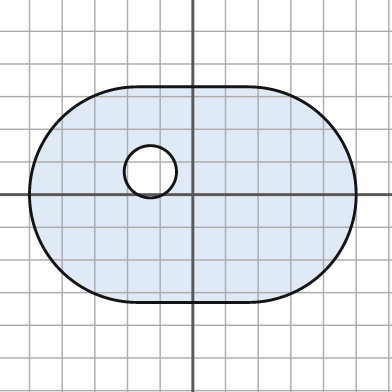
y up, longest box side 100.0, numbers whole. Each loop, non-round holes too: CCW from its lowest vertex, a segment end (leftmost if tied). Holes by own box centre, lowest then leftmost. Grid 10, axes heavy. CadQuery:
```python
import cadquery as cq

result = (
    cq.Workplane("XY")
    .moveTo(-17.0, -33.0)
    .lineTo(17.0, -33.0)
    .threePointArc((50.0, 0.0), (17.0, 33.0))
    .lineTo(-17.0, 33.0)
    .threePointArc((-50.0, 0.0), (-17.0, -33.0))
    .close()
    .moveTo(-13.0, 7.0)
    .circle(8.0)
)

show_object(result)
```